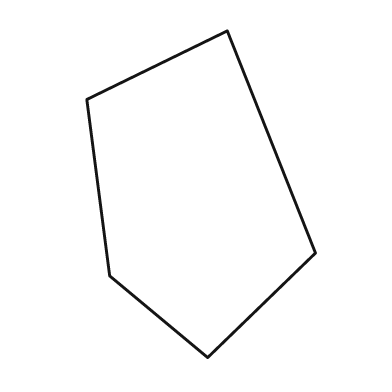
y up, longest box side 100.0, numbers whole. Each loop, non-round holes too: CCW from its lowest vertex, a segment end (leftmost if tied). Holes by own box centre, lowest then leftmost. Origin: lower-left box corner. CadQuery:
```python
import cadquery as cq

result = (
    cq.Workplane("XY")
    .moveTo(37.0, 0.0)
    .lineTo(70.0, 32.0)
    .lineTo(43.0, 100.0)
    .lineTo(0.0, 79.0)
    .lineTo(7.0, 25.0)
    .close()
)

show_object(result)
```